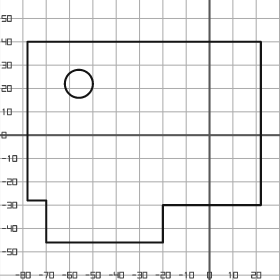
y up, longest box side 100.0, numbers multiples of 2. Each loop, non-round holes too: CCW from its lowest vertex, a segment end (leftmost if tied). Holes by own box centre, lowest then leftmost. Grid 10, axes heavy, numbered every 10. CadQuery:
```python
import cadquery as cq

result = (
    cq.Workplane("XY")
    .moveTo(-70.0, -46.0)
    .lineTo(-20.0, -46.0)
    .lineTo(-20.0, -30.0)
    .lineTo(22.0, -30.0)
    .lineTo(22.0, 40.0)
    .lineTo(-78.0, 40.0)
    .lineTo(-78.0, -28.0)
    .lineTo(-70.0, -28.0)
    .close()
    .moveTo(-56.0, 22.0)
    .circle(6.0)
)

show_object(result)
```